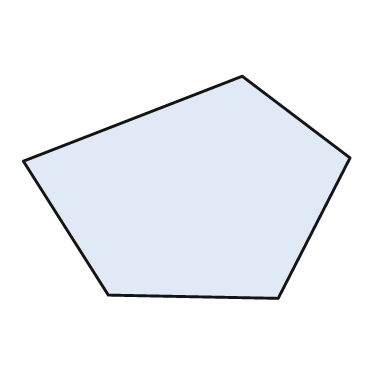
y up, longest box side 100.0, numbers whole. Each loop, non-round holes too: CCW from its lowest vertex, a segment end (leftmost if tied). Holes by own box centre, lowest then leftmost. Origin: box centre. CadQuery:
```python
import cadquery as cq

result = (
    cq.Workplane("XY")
    .moveTo(28.0, -34.0)
    .lineTo(50.0, 9.0)
    .lineTo(17.0, 34.0)
    .lineTo(-50.0, 8.0)
    .lineTo(-24.0, -33.0)
    .close()
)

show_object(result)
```